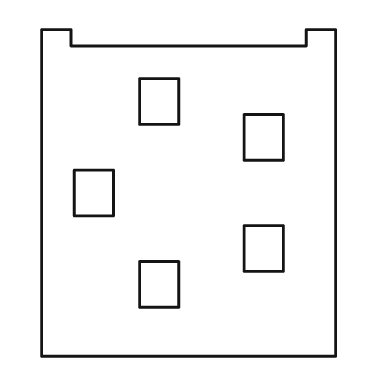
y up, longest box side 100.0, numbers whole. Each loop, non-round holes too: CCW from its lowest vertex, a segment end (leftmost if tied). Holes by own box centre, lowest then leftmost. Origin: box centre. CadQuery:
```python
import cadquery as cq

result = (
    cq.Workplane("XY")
    .moveTo(-45.0, -50.0)
    .lineTo(45.0, -50.0)
    .lineTo(45.0, 50.0)
    .lineTo(36.0, 50.0)
    .lineTo(36.0, 45.0)
    .lineTo(-36.0, 45.0)
    .lineTo(-36.0, 50.0)
    .lineTo(-45.0, 50.0)
    .close()
    .moveTo(-15.0, -35.0)
    .lineTo(-3.0, -35.0)
    .lineTo(-3.0, -21.0)
    .lineTo(-15.0, -21.0)
    .close()
    .moveTo(17.0, -24.0)
    .lineTo(29.0, -24.0)
    .lineTo(29.0, -10.0)
    .lineTo(17.0, -10.0)
    .close()
    .moveTo(-35.0, -7.0)
    .lineTo(-23.0, -7.0)
    .lineTo(-23.0, 7.0)
    .lineTo(-35.0, 7.0)
    .close()
    .moveTo(17.0, 10.0)
    .lineTo(29.0, 10.0)
    .lineTo(29.0, 24.0)
    .lineTo(17.0, 24.0)
    .close()
    .moveTo(-15.0, 21.0)
    .lineTo(-3.0, 21.0)
    .lineTo(-3.0, 35.0)
    .lineTo(-15.0, 35.0)
    .close()
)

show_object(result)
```